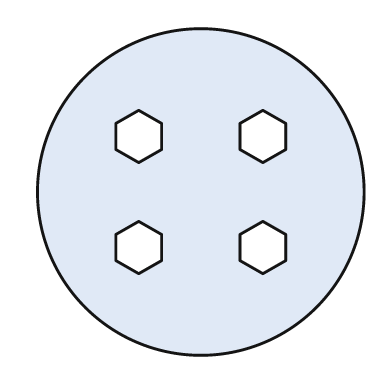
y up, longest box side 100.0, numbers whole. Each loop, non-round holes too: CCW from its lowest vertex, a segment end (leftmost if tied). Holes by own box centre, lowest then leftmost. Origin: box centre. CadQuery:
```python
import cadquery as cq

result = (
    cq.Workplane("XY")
    .moveTo(0.0, 0.0)
    .circle(50.0)
    .moveTo(-19.0, -25.0)
    .lineTo(-12.0, -21.0)
    .lineTo(-12.0, -13.0)
    .lineTo(-19.0, -9.0)
    .lineTo(-26.0, -13.0)
    .lineTo(-26.0, -21.0)
    .close()
    .moveTo(19.0, -25.0)
    .lineTo(26.0, -21.0)
    .lineTo(26.0, -13.0)
    .lineTo(19.0, -9.0)
    .lineTo(12.0, -13.0)
    .lineTo(12.0, -21.0)
    .close()
    .moveTo(-19.0, 9.0)
    .lineTo(-12.0, 13.0)
    .lineTo(-12.0, 21.0)
    .lineTo(-19.0, 25.0)
    .lineTo(-26.0, 21.0)
    .lineTo(-26.0, 13.0)
    .close()
    .moveTo(19.0, 9.0)
    .lineTo(26.0, 13.0)
    .lineTo(26.0, 21.0)
    .lineTo(19.0, 25.0)
    .lineTo(12.0, 21.0)
    .lineTo(12.0, 13.0)
    .close()
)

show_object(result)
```